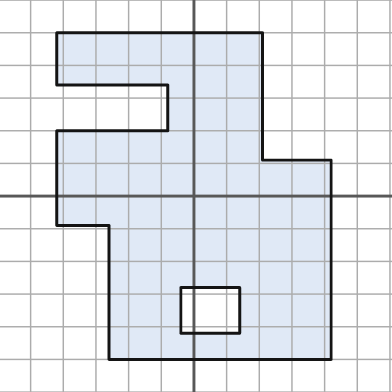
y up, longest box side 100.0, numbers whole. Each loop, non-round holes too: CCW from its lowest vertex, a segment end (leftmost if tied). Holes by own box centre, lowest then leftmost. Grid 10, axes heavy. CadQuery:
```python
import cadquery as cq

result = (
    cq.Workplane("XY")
    .moveTo(-26.0, -50.0)
    .lineTo(42.0, -50.0)
    .lineTo(42.0, 11.0)
    .lineTo(21.0, 11.0)
    .lineTo(21.0, 50.0)
    .lineTo(-42.0, 50.0)
    .lineTo(-42.0, 34.0)
    .lineTo(-8.0, 34.0)
    .lineTo(-8.0, 20.0)
    .lineTo(-42.0, 20.0)
    .lineTo(-42.0, -9.0)
    .lineTo(-26.0, -9.0)
    .close()
    .moveTo(-4.0, -42.0)
    .lineTo(14.0, -42.0)
    .lineTo(14.0, -28.0)
    .lineTo(-4.0, -28.0)
    .close()
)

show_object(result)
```